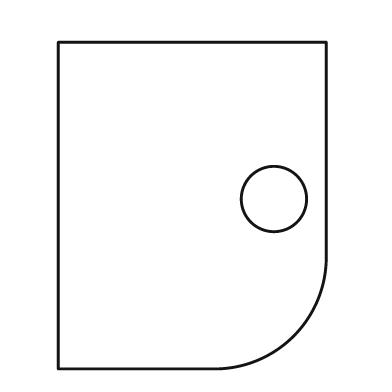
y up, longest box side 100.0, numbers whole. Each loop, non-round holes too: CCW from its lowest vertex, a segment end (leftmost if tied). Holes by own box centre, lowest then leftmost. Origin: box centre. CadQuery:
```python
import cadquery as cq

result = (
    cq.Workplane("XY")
    .moveTo(-41.0, -50.0)
    .lineTo(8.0, -50.0)
    .threePointArc((31.0, -40.0), (41.0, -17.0))
    .lineTo(41.0, 50.0)
    .lineTo(-41.0, 50.0)
    .close()
    .moveTo(25.0, 2.0)
    .circle(10.0)
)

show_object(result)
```